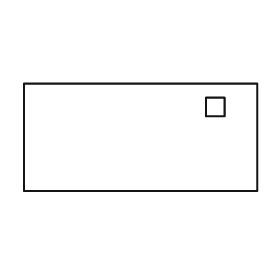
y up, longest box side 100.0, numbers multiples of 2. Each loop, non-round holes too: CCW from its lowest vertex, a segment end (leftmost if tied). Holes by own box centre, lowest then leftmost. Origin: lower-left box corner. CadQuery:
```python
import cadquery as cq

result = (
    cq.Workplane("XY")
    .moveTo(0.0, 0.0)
    .lineTo(100.0, 0.0)
    .lineTo(100.0, 46.0)
    .lineTo(0.0, 46.0)
    .close()
    .moveTo(78.0, 32.0)
    .lineTo(86.0, 32.0)
    .lineTo(86.0, 40.0)
    .lineTo(78.0, 40.0)
    .close()
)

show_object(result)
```